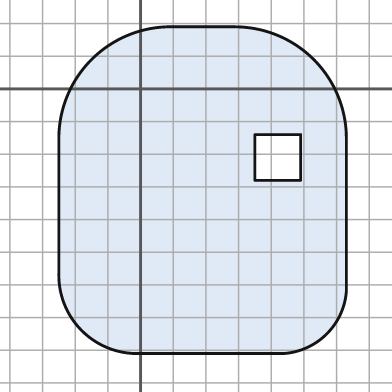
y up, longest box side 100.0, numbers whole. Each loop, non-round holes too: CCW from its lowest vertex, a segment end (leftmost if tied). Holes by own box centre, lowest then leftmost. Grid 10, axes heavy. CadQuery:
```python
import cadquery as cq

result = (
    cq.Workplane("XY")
    .moveTo(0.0, -81.0)
    .lineTo(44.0, -81.0)
    .threePointArc((57.0, -75.0), (63.0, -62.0))
    .lineTo(63.0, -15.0)
    .threePointArc((53.0, 9.0), (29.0, 19.0))
    .lineTo(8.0, 19.0)
    .threePointArc((-15.0, 9.0), (-25.0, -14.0))
    .lineTo(-25.0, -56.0)
    .threePointArc((-18.0, -74.0), (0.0, -81.0))
    .close()
    .moveTo(35.0, -28.0)
    .lineTo(49.0, -28.0)
    .lineTo(49.0, -14.0)
    .lineTo(35.0, -14.0)
    .close()
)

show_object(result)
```